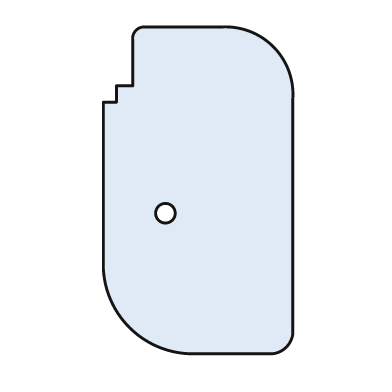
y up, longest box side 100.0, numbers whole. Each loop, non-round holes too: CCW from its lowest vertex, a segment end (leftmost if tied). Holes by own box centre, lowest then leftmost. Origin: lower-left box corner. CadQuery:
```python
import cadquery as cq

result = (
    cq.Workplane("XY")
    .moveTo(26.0, 0.0)
    .lineTo(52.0, 0.0)
    .threePointArc((56.0, 2.0), (58.0, 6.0))
    .lineTo(58.0, 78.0)
    .threePointArc((52.0, 94.0), (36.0, 100.0))
    .lineTo(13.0, 100.0)
    .threePointArc((10.0, 99.0), (9.0, 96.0))
    .lineTo(9.0, 82.0)
    .lineTo(4.0, 82.0)
    .lineTo(4.0, 77.0)
    .lineTo(0.0, 77.0)
    .lineTo(0.0, 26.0)
    .threePointArc((8.0, 8.0), (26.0, 0.0))
    .close()
    .moveTo(19.0, 43.0)
    .circle(3.0)
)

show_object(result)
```